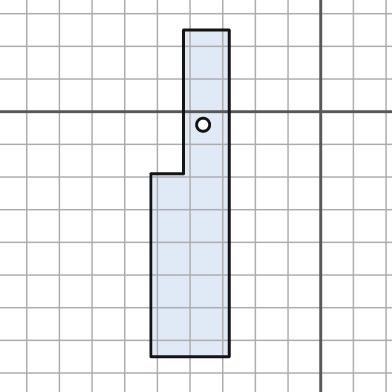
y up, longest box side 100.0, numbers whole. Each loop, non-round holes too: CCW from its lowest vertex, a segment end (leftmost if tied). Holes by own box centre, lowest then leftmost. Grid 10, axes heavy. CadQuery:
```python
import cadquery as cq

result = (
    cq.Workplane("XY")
    .moveTo(-52.0, -75.0)
    .lineTo(-28.0, -75.0)
    .lineTo(-28.0, 25.0)
    .lineTo(-42.0, 25.0)
    .lineTo(-42.0, -19.0)
    .lineTo(-52.0, -19.0)
    .close()
    .moveTo(-36.0, -4.0)
    .circle(2.0)
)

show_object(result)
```